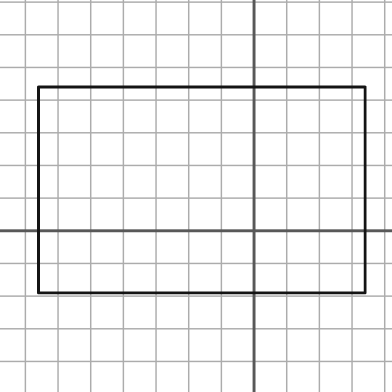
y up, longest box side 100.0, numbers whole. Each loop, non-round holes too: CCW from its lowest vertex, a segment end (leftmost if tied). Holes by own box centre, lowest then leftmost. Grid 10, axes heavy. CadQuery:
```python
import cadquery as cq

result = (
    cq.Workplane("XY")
    .moveTo(-66.0, -19.0)
    .lineTo(34.0, -19.0)
    .lineTo(34.0, 44.0)
    .lineTo(-66.0, 44.0)
    .close()
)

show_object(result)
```